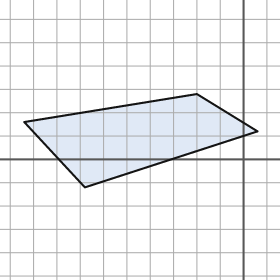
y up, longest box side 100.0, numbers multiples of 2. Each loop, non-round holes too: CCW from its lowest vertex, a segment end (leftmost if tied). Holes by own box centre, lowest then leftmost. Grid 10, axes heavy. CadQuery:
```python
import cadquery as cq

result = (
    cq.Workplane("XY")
    .moveTo(-68.0, -12.0)
    .lineTo(6.0, 12.0)
    .lineTo(-20.0, 28.0)
    .lineTo(-94.0, 16.0)
    .close()
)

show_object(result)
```